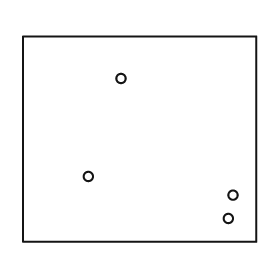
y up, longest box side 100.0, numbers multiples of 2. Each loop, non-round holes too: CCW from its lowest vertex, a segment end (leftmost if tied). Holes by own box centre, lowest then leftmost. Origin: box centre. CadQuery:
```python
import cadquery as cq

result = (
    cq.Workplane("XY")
    .moveTo(-50.0, -44.0)
    .lineTo(50.0, -44.0)
    .lineTo(50.0, 44.0)
    .lineTo(-50.0, 44.0)
    .close()
    .moveTo(38.0, -34.0)
    .circle(2.0)
    .moveTo(40.0, -24.0)
    .circle(2.0)
    .moveTo(-22.0, -16.0)
    .circle(2.0)
    .moveTo(-8.0, 26.0)
    .circle(2.0)
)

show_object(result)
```